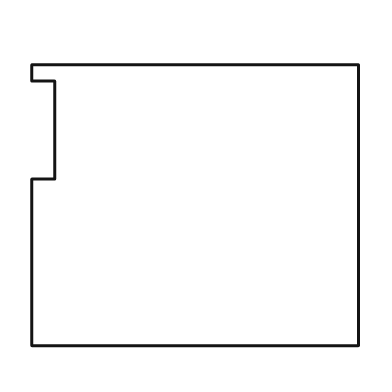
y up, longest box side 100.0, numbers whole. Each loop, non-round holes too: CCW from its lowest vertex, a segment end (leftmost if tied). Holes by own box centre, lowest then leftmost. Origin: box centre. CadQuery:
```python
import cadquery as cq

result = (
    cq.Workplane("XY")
    .moveTo(-50.0, -43.0)
    .lineTo(50.0, -43.0)
    .lineTo(50.0, 43.0)
    .lineTo(-50.0, 43.0)
    .lineTo(-50.0, 38.0)
    .lineTo(-43.0, 38.0)
    .lineTo(-43.0, 8.0)
    .lineTo(-50.0, 8.0)
    .close()
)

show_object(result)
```